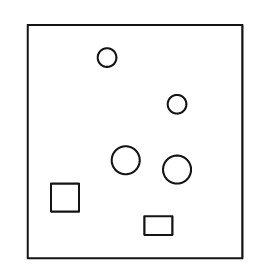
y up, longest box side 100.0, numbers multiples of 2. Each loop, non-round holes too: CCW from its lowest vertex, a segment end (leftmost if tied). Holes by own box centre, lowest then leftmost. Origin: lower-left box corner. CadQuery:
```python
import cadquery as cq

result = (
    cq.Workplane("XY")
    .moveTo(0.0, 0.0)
    .lineTo(92.0, 0.0)
    .lineTo(92.0, 100.0)
    .lineTo(0.0, 100.0)
    .close()
    .moveTo(50.0, 10.0)
    .lineTo(62.0, 10.0)
    .lineTo(62.0, 18.0)
    .lineTo(50.0, 18.0)
    .close()
    .moveTo(10.0, 20.0)
    .lineTo(22.0, 20.0)
    .lineTo(22.0, 32.0)
    .lineTo(10.0, 32.0)
    .close()
    .moveTo(64.0, 38.0)
    .circle(6.0)
    .moveTo(42.0, 42.0)
    .circle(6.0)
    .moveTo(64.0, 66.0)
    .circle(4.0)
    .moveTo(34.0, 86.0)
    .circle(4.0)
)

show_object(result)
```